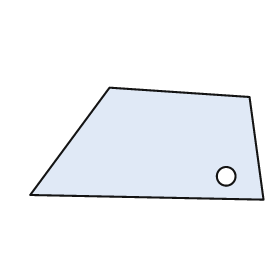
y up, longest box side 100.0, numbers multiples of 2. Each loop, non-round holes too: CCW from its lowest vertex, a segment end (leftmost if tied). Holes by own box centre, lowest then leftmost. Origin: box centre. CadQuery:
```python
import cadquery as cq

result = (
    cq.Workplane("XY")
    .moveTo(50.0, -24.0)
    .lineTo(44.0, 20.0)
    .lineTo(-16.0, 24.0)
    .lineTo(-50.0, -22.0)
    .close()
    .moveTo(34.0, -14.0)
    .circle(4.0)
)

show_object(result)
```